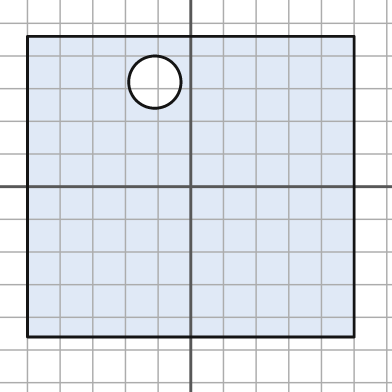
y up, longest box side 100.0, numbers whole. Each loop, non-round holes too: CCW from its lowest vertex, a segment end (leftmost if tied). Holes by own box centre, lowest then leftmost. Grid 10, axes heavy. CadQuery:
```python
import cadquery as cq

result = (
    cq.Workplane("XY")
    .moveTo(-50.0, -46.0)
    .lineTo(50.0, -46.0)
    .lineTo(50.0, 46.0)
    .lineTo(-50.0, 46.0)
    .close()
    .moveTo(-11.0, 32.0)
    .circle(8.0)
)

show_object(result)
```